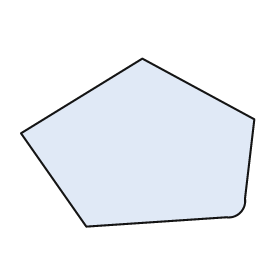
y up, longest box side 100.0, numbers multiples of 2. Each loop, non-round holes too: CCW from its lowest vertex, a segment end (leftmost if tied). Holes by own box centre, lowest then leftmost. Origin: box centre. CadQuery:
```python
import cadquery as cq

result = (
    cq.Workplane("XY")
    .moveTo(-22.0, -36.0)
    .lineTo(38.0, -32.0)
    .threePointArc((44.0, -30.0), (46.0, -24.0))
    .lineTo(50.0, 10.0)
    .lineTo(2.0, 36.0)
    .lineTo(-50.0, 4.0)
    .close()
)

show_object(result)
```